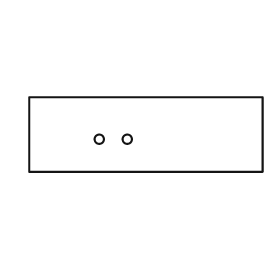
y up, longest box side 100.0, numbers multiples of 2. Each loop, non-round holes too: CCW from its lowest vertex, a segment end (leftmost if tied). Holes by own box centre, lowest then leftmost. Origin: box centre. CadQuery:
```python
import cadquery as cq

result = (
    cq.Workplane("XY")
    .moveTo(-50.0, -16.0)
    .lineTo(50.0, -16.0)
    .lineTo(50.0, 16.0)
    .lineTo(-50.0, 16.0)
    .close()
    .moveTo(-20.0, -2.0)
    .circle(2.0)
    .moveTo(-8.0, -2.0)
    .circle(2.0)
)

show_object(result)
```